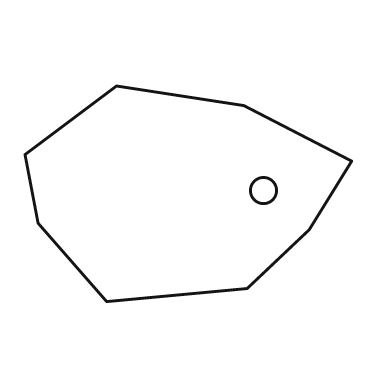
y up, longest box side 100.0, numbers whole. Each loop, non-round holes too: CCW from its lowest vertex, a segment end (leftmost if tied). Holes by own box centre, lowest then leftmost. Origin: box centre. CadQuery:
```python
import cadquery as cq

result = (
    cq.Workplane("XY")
    .moveTo(-25.0, -33.0)
    .lineTo(18.0, -29.0)
    .lineTo(37.0, -11.0)
    .lineTo(50.0, 10.0)
    .lineTo(17.0, 27.0)
    .lineTo(-22.0, 33.0)
    .lineTo(-50.0, 12.0)
    .lineTo(-46.0, -9.0)
    .close()
    .moveTo(23.0, 1.0)
    .circle(4.0)
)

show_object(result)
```